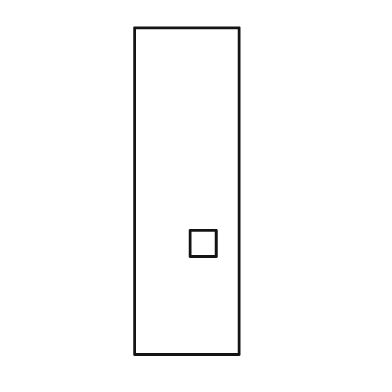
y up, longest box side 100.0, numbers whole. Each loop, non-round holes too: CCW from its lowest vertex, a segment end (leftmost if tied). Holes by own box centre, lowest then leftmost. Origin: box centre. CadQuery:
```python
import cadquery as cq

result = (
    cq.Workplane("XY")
    .moveTo(-16.0, -50.0)
    .lineTo(16.0, -50.0)
    .lineTo(16.0, 50.0)
    .lineTo(-16.0, 50.0)
    .close()
    .moveTo(1.0, -20.0)
    .lineTo(9.0, -20.0)
    .lineTo(9.0, -12.0)
    .lineTo(1.0, -12.0)
    .close()
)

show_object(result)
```